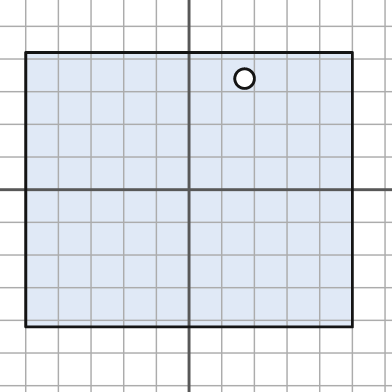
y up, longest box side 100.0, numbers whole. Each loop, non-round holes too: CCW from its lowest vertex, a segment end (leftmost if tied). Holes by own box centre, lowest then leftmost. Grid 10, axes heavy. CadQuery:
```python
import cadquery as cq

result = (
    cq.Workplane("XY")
    .moveTo(-50.0, -42.0)
    .lineTo(50.0, -42.0)
    .lineTo(50.0, 42.0)
    .lineTo(-50.0, 42.0)
    .close()
    .moveTo(17.0, 34.0)
    .circle(3.0)
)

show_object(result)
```